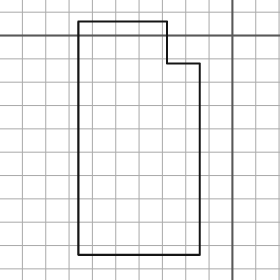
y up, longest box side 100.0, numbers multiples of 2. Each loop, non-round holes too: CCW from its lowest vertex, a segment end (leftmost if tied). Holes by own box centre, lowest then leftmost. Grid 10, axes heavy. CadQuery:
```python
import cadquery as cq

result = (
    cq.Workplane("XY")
    .moveTo(-66.0, -94.0)
    .lineTo(-14.0, -94.0)
    .lineTo(-14.0, -12.0)
    .lineTo(-28.0, -12.0)
    .lineTo(-28.0, 6.0)
    .lineTo(-66.0, 6.0)
    .close()
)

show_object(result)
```